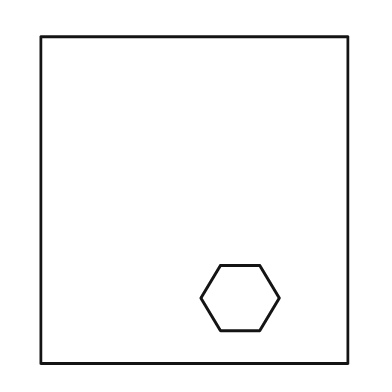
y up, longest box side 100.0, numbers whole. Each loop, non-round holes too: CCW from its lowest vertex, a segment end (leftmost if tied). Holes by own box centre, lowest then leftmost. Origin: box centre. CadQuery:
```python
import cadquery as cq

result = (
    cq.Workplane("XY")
    .moveTo(-47.0, -50.0)
    .lineTo(47.0, -50.0)
    .lineTo(47.0, 50.0)
    .lineTo(-47.0, 50.0)
    .close()
    .moveTo(8.0, -40.0)
    .lineTo(20.0, -40.0)
    .lineTo(26.0, -30.0)
    .lineTo(20.0, -20.0)
    .lineTo(8.0, -20.0)
    .lineTo(2.0, -30.0)
    .close()
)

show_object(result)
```